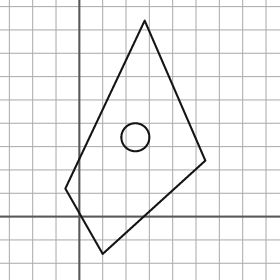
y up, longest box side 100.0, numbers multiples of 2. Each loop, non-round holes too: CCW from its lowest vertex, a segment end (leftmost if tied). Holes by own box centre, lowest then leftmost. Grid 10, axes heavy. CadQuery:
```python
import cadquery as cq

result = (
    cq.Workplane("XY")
    .moveTo(10.0, -16.0)
    .lineTo(54.0, 24.0)
    .lineTo(28.0, 84.0)
    .lineTo(-6.0, 12.0)
    .close()
    .moveTo(24.0, 34.0)
    .circle(6.0)
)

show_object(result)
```